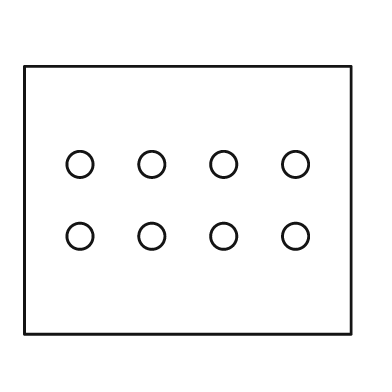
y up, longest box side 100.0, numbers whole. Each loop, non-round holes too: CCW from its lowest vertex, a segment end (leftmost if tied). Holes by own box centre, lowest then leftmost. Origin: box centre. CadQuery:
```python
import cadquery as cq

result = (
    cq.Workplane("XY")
    .moveTo(-50.0, -41.0)
    .lineTo(50.0, -41.0)
    .lineTo(50.0, 41.0)
    .lineTo(-50.0, 41.0)
    .close()
    .moveTo(-33.0, -11.0)
    .circle(4.0)
    .moveTo(-11.0, -11.0)
    .circle(4.0)
    .moveTo(11.0, -11.0)
    .circle(4.0)
    .moveTo(33.0, -11.0)
    .circle(4.0)
    .moveTo(-33.0, 11.0)
    .circle(4.0)
    .moveTo(-11.0, 11.0)
    .circle(4.0)
    .moveTo(11.0, 11.0)
    .circle(4.0)
    .moveTo(33.0, 11.0)
    .circle(4.0)
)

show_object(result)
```